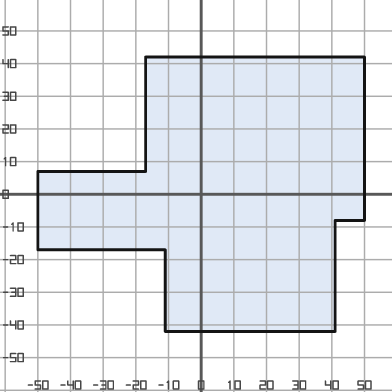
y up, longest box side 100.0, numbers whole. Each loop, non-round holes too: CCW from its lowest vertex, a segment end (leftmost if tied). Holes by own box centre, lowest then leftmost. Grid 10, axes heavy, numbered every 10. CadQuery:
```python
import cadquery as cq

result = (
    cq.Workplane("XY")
    .moveTo(-11.0, -42.0)
    .lineTo(41.0, -42.0)
    .lineTo(41.0, -8.0)
    .lineTo(50.0, -8.0)
    .lineTo(50.0, 42.0)
    .lineTo(-17.0, 42.0)
    .lineTo(-17.0, 7.0)
    .lineTo(-50.0, 7.0)
    .lineTo(-50.0, -17.0)
    .lineTo(-11.0, -17.0)
    .close()
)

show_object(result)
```